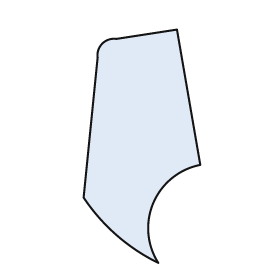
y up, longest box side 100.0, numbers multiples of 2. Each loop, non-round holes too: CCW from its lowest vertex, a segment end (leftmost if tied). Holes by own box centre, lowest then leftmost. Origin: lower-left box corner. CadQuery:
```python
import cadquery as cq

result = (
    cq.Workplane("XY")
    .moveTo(32.0, 0.0)
    .threePointArc((30.0, 26.0), (50.0, 42.0))
    .lineTo(40.0, 100.0)
    .lineTo(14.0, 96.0)
    .threePointArc((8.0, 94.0), (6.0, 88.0))
    .lineTo(0.0, 28.0)
    .threePointArc((14.0, 12.0), (32.0, 0.0))
    .close()
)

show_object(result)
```